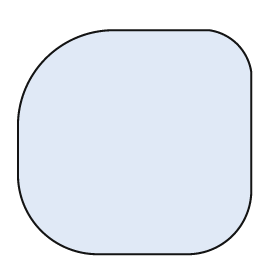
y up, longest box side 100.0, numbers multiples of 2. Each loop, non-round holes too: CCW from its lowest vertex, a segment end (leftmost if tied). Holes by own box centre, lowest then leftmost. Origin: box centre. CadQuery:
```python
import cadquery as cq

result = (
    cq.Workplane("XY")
    .moveTo(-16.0, -48.0)
    .lineTo(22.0, -48.0)
    .threePointArc((42.0, -40.0), (50.0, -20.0))
    .lineTo(50.0, 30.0)
    .threePointArc((44.0, 42.0), (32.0, 48.0))
    .lineTo(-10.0, 48.0)
    .threePointArc((-38.0, 36.0), (-50.0, 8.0))
    .lineTo(-50.0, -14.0)
    .threePointArc((-40.0, -38.0), (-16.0, -48.0))
    .close()
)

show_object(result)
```